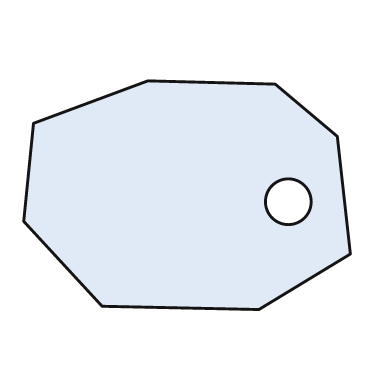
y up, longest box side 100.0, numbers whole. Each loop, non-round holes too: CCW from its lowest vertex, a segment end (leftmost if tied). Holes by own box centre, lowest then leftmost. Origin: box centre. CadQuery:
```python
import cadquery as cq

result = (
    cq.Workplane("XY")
    .moveTo(22.0, -35.0)
    .lineTo(50.0, -18.0)
    .lineTo(46.0, 18.0)
    .lineTo(27.0, 34.0)
    .lineTo(-12.0, 35.0)
    .lineTo(-47.0, 22.0)
    .lineTo(-50.0, -8.0)
    .lineTo(-26.0, -34.0)
    .close()
    .moveTo(31.0, -2.0)
    .circle(7.0)
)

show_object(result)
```